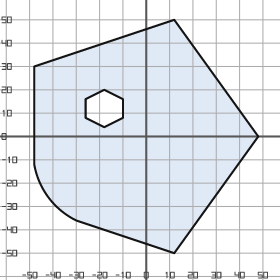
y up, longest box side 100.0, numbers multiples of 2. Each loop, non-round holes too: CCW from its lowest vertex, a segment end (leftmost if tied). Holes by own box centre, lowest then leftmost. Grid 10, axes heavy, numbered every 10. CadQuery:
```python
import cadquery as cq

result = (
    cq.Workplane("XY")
    .moveTo(12.0, -50.0)
    .lineTo(48.0, 0.0)
    .lineTo(12.0, 50.0)
    .lineTo(-48.0, 30.0)
    .lineTo(-48.0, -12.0)
    .threePointArc((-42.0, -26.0), (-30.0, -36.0))
    .close()
    .moveTo(-18.0, 4.0)
    .lineTo(-10.0, 8.0)
    .lineTo(-10.0, 16.0)
    .lineTo(-18.0, 20.0)
    .lineTo(-26.0, 16.0)
    .lineTo(-26.0, 8.0)
    .close()
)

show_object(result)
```